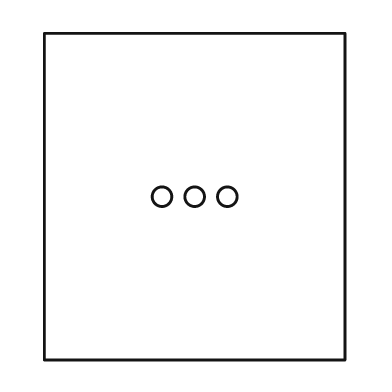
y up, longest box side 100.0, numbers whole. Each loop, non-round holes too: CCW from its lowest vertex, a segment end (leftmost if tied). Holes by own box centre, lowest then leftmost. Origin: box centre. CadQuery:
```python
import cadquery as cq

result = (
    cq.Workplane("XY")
    .moveTo(-46.0, -50.0)
    .lineTo(46.0, -50.0)
    .lineTo(46.0, 50.0)
    .lineTo(-46.0, 50.0)
    .close()
    .moveTo(-10.0, 0.0)
    .circle(3.0)
    .moveTo(0.0, 0.0)
    .circle(3.0)
    .moveTo(10.0, 0.0)
    .circle(3.0)
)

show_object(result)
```